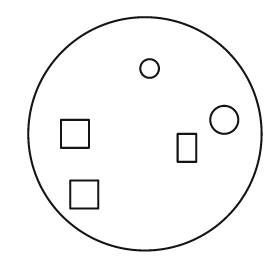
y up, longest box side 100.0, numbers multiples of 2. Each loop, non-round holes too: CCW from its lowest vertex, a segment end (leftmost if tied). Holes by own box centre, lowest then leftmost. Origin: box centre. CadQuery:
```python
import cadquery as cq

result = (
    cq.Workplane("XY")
    .moveTo(0.0, 0.0)
    .circle(50.0)
    .moveTo(-32.0, -32.0)
    .lineTo(-20.0, -32.0)
    .lineTo(-20.0, -20.0)
    .lineTo(-32.0, -20.0)
    .close()
    .moveTo(14.0, -12.0)
    .lineTo(22.0, -12.0)
    .lineTo(22.0, 0.0)
    .lineTo(14.0, 0.0)
    .close()
    .moveTo(-36.0, -6.0)
    .lineTo(-24.0, -6.0)
    .lineTo(-24.0, 6.0)
    .lineTo(-36.0, 6.0)
    .close()
    .moveTo(34.0, 6.0)
    .circle(6.0)
    .moveTo(2.0, 28.0)
    .circle(4.0)
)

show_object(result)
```